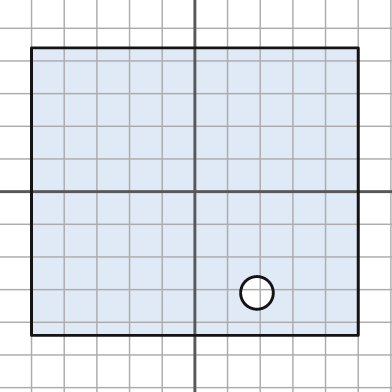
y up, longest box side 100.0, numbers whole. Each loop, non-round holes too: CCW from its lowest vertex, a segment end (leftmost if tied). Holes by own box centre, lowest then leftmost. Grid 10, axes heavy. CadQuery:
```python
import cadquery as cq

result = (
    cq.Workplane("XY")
    .moveTo(-50.0, -44.0)
    .lineTo(50.0, -44.0)
    .lineTo(50.0, 44.0)
    .lineTo(-50.0, 44.0)
    .close()
    .moveTo(19.0, -31.0)
    .circle(5.0)
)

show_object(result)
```